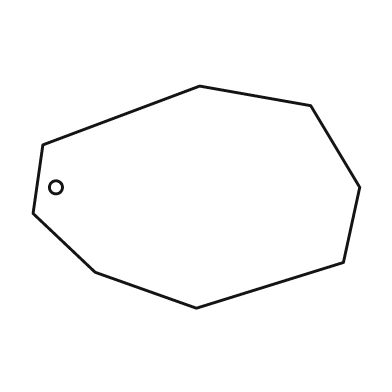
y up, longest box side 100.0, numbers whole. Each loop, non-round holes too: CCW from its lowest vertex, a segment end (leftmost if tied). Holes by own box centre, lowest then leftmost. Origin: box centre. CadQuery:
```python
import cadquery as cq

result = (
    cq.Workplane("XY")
    .moveTo(0.0, -34.0)
    .lineTo(45.0, -20.0)
    .lineTo(50.0, 3.0)
    .lineTo(35.0, 28.0)
    .lineTo(1.0, 34.0)
    .lineTo(-47.0, 16.0)
    .lineTo(-50.0, -5.0)
    .lineTo(-31.0, -23.0)
    .close()
    .moveTo(-43.0, 3.0)
    .circle(2.0)
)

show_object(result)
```